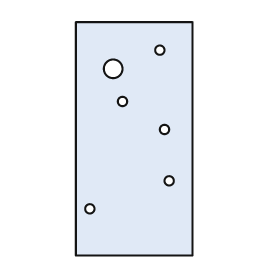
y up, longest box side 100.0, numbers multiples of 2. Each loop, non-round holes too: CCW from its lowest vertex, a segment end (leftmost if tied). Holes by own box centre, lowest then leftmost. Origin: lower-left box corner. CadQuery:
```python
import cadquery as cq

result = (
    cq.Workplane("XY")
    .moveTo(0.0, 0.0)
    .lineTo(50.0, 0.0)
    .lineTo(50.0, 100.0)
    .lineTo(0.0, 100.0)
    .close()
    .moveTo(6.0, 20.0)
    .circle(2.0)
    .moveTo(40.0, 32.0)
    .circle(2.0)
    .moveTo(38.0, 54.0)
    .circle(2.0)
    .moveTo(20.0, 66.0)
    .circle(2.0)
    .moveTo(16.0, 80.0)
    .circle(4.0)
    .moveTo(36.0, 88.0)
    .circle(2.0)
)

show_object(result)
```